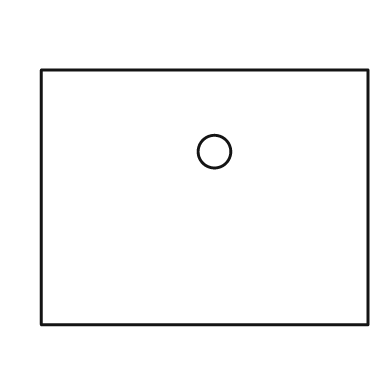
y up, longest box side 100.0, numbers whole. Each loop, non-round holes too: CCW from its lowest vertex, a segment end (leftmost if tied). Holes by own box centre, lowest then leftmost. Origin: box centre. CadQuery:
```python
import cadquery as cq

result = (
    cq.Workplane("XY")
    .moveTo(-50.0, -39.0)
    .lineTo(50.0, -39.0)
    .lineTo(50.0, 39.0)
    .lineTo(-50.0, 39.0)
    .close()
    .moveTo(3.0, 14.0)
    .circle(5.0)
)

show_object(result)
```